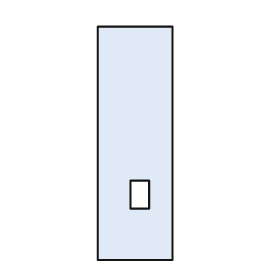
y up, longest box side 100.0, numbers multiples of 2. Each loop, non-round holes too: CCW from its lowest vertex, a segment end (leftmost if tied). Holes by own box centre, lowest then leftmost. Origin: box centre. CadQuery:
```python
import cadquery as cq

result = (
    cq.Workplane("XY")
    .moveTo(-16.0, -50.0)
    .lineTo(16.0, -50.0)
    .lineTo(16.0, 50.0)
    .lineTo(-16.0, 50.0)
    .close()
    .moveTo(-2.0, -28.0)
    .lineTo(6.0, -28.0)
    .lineTo(6.0, -16.0)
    .lineTo(-2.0, -16.0)
    .close()
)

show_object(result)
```